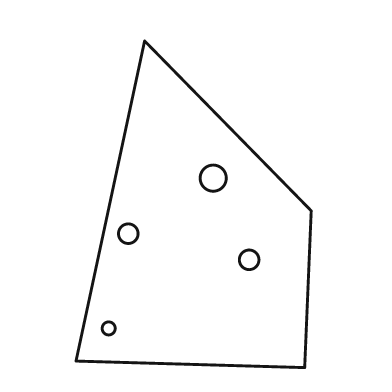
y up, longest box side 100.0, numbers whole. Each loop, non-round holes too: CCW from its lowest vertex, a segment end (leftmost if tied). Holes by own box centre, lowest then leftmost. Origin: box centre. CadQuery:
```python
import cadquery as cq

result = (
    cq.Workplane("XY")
    .moveTo(34.0, -50.0)
    .lineTo(36.0, -2.0)
    .lineTo(-15.0, 50.0)
    .lineTo(-36.0, -48.0)
    .close()
    .moveTo(-26.0, -38.0)
    .circle(2.0)
    .moveTo(17.0, -17.0)
    .circle(3.0)
    .moveTo(-20.0, -9.0)
    .circle(3.0)
    .moveTo(6.0, 8.0)
    .circle(4.0)
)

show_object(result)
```